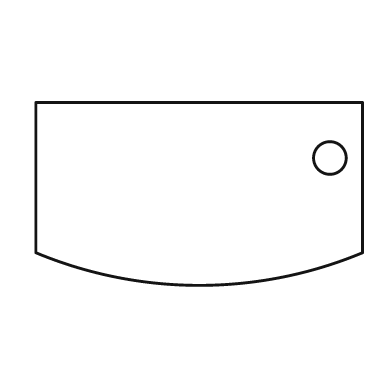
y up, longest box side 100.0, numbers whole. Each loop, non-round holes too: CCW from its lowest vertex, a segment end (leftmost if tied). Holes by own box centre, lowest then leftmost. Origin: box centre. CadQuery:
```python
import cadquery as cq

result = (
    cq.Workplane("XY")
    .moveTo(-50.0, -18.0)
    .threePointArc((0.0, -28.0), (50.0, -18.0))
    .lineTo(50.0, 28.0)
    .lineTo(-50.0, 28.0)
    .close()
    .moveTo(40.0, 11.0)
    .circle(5.0)
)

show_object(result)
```